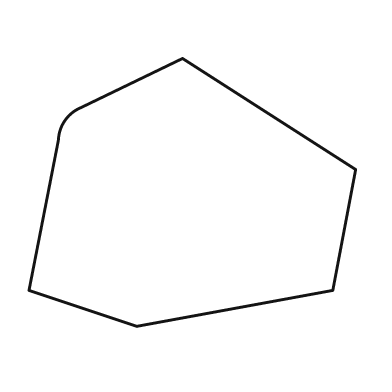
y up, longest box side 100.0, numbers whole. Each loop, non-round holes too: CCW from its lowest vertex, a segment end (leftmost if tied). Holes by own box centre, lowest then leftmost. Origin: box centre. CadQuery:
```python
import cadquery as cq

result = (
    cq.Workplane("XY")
    .moveTo(-17.0, -41.0)
    .lineTo(43.0, -30.0)
    .lineTo(50.0, 7.0)
    .lineTo(-3.0, 41.0)
    .lineTo(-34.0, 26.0)
    .threePointArc((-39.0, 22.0), (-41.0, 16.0))
    .lineTo(-50.0, -30.0)
    .close()
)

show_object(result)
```